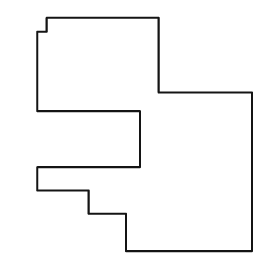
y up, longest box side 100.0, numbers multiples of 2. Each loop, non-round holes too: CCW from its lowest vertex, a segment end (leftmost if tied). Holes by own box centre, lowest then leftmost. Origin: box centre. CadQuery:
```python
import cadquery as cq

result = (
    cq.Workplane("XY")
    .moveTo(-8.0, -50.0)
    .lineTo(46.0, -50.0)
    .lineTo(46.0, 18.0)
    .lineTo(6.0, 18.0)
    .lineTo(6.0, 50.0)
    .lineTo(-42.0, 50.0)
    .lineTo(-42.0, 44.0)
    .lineTo(-46.0, 44.0)
    .lineTo(-46.0, 10.0)
    .lineTo(-2.0, 10.0)
    .lineTo(-2.0, -14.0)
    .lineTo(-46.0, -14.0)
    .lineTo(-46.0, -24.0)
    .lineTo(-24.0, -24.0)
    .lineTo(-24.0, -34.0)
    .lineTo(-8.0, -34.0)
    .close()
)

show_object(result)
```